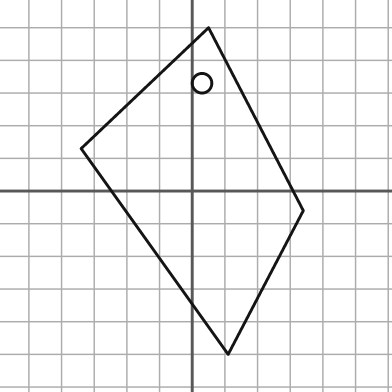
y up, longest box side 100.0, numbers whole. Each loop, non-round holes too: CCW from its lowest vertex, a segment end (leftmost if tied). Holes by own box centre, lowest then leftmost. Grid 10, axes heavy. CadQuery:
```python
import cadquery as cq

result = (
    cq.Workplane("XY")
    .moveTo(11.0, -50.0)
    .lineTo(34.0, -6.0)
    .lineTo(5.0, 50.0)
    .lineTo(-34.0, 13.0)
    .close()
    .moveTo(3.0, 33.0)
    .circle(3.0)
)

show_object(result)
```